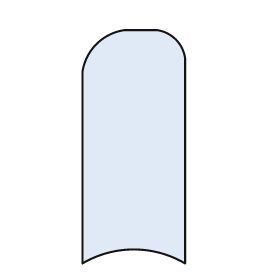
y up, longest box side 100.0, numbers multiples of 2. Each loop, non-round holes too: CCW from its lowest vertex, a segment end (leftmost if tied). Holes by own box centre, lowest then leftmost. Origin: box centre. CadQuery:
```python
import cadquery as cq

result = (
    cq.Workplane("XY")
    .moveTo(-22.0, -50.0)
    .threePointArc((0.0, -44.0), (22.0, -50.0))
    .lineTo(22.0, 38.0)
    .threePointArc((18.0, 46.0), (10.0, 50.0))
    .lineTo(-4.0, 50.0)
    .threePointArc((-16.0, 44.0), (-22.0, 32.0))
    .close()
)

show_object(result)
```